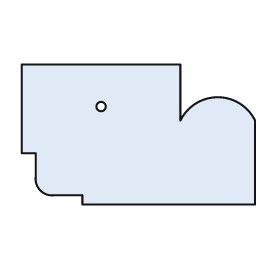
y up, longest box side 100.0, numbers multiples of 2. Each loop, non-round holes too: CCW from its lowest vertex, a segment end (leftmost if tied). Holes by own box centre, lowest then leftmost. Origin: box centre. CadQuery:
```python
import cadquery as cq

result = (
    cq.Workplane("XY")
    .moveTo(-24.0, -30.0)
    .lineTo(50.0, -30.0)
    .lineTo(50.0, 6.0)
    .threePointArc((34.0, 16.0), (18.0, 6.0))
    .lineTo(18.0, 30.0)
    .lineTo(-50.0, 30.0)
    .lineTo(-50.0, -8.0)
    .lineTo(-44.0, -8.0)
    .lineTo(-44.0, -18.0)
    .threePointArc((-42.0, -24.0), (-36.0, -26.0))
    .lineTo(-24.0, -26.0)
    .close()
    .moveTo(-16.0, 12.0)
    .circle(2.0)
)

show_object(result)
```